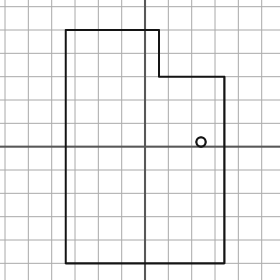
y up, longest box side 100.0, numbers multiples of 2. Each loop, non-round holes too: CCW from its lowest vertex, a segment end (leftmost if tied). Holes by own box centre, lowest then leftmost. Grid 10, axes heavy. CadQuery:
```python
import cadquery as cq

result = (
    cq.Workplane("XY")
    .moveTo(-34.0, -50.0)
    .lineTo(34.0, -50.0)
    .lineTo(34.0, 30.0)
    .lineTo(6.0, 30.0)
    .lineTo(6.0, 50.0)
    .lineTo(-34.0, 50.0)
    .close()
    .moveTo(24.0, 2.0)
    .circle(2.0)
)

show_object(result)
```